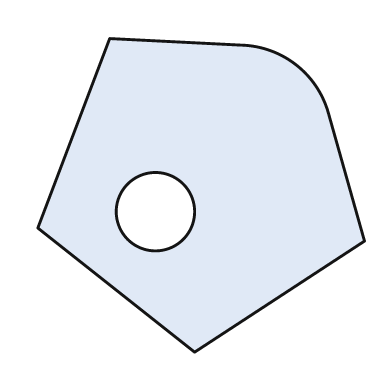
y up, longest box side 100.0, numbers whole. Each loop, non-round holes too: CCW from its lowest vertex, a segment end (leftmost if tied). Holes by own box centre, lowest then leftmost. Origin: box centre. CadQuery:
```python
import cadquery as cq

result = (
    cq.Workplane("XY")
    .moveTo(-2.0, -48.0)
    .lineTo(50.0, -14.0)
    .lineTo(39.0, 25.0)
    .threePointArc((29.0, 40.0), (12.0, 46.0))
    .lineTo(-28.0, 48.0)
    .lineTo(-50.0, -10.0)
    .close()
    .moveTo(-14.0, -5.0)
    .circle(12.0)
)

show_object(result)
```